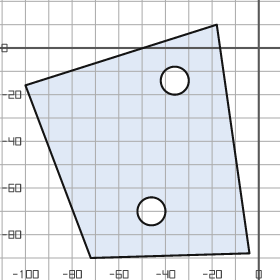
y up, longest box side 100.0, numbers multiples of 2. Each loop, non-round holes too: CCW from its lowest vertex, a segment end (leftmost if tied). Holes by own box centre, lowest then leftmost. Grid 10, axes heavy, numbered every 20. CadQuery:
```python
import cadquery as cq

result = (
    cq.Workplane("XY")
    .moveTo(-72.0, -90.0)
    .lineTo(-4.0, -88.0)
    .lineTo(-18.0, 10.0)
    .lineTo(-100.0, -16.0)
    .close()
    .moveTo(-46.0, -70.0)
    .circle(6.0)
    .moveTo(-36.0, -14.0)
    .circle(6.0)
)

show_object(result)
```